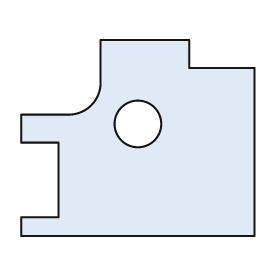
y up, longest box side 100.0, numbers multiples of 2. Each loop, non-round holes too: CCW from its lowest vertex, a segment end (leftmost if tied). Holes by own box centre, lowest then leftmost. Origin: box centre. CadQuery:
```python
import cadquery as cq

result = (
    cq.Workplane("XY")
    .moveTo(-50.0, -42.0)
    .lineTo(50.0, -42.0)
    .lineTo(50.0, 30.0)
    .lineTo(22.0, 30.0)
    .lineTo(22.0, 42.0)
    .lineTo(-16.0, 42.0)
    .lineTo(-16.0, 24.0)
    .threePointArc((-20.0, 14.0), (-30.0, 10.0))
    .lineTo(-50.0, 10.0)
    .lineTo(-50.0, -2.0)
    .lineTo(-34.0, -2.0)
    .lineTo(-34.0, -34.0)
    .lineTo(-50.0, -34.0)
    .close()
    .moveTo(0.0, 6.0)
    .circle(10.0)
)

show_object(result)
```